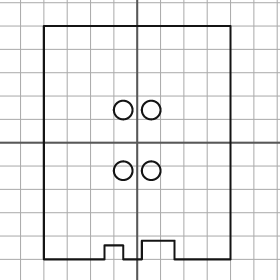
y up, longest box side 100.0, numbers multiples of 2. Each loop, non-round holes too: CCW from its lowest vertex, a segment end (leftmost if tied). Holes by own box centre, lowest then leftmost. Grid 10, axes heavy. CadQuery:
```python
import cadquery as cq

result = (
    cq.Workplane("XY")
    .moveTo(-40.0, -50.0)
    .lineTo(-14.0, -50.0)
    .lineTo(-14.0, -44.0)
    .lineTo(-6.0, -44.0)
    .lineTo(-6.0, -50.0)
    .lineTo(2.0, -50.0)
    .lineTo(2.0, -42.0)
    .lineTo(16.0, -42.0)
    .lineTo(16.0, -50.0)
    .lineTo(40.0, -50.0)
    .lineTo(40.0, 50.0)
    .lineTo(-40.0, 50.0)
    .close()
    .moveTo(-6.0, -12.0)
    .circle(4.0)
    .moveTo(6.0, -12.0)
    .circle(4.0)
    .moveTo(-6.0, 14.0)
    .circle(4.0)
    .moveTo(6.0, 14.0)
    .circle(4.0)
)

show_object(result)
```